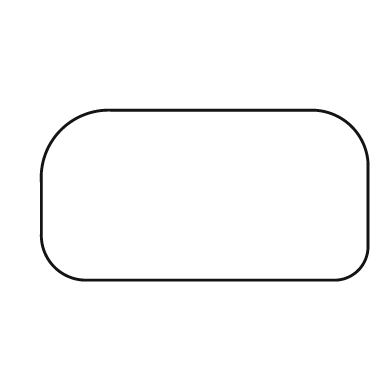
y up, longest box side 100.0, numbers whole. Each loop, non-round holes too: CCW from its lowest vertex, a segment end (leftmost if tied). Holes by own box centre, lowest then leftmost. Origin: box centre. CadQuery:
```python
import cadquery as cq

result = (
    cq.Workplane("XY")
    .moveTo(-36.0, -26.0)
    .lineTo(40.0, -26.0)
    .threePointArc((47.0, -23.0), (50.0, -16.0))
    .lineTo(50.0, 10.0)
    .threePointArc((45.0, 21.0), (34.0, 26.0))
    .lineTo(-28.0, 26.0)
    .threePointArc((-44.0, 20.0), (-50.0, 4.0))
    .lineTo(-50.0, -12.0)
    .threePointArc((-46.0, -22.0), (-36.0, -26.0))
    .close()
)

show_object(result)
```